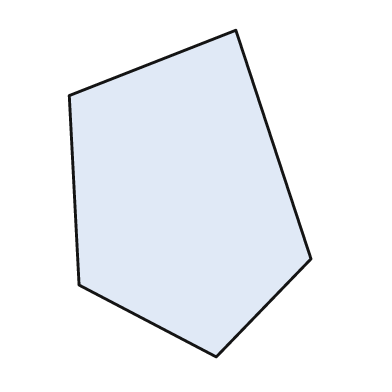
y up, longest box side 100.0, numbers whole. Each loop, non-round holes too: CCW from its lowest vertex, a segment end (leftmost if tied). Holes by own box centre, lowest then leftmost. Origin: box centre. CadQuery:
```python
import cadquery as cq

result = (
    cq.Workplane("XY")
    .moveTo(8.0, -50.0)
    .lineTo(37.0, -20.0)
    .lineTo(14.0, 50.0)
    .lineTo(-37.0, 30.0)
    .lineTo(-34.0, -28.0)
    .close()
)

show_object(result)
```